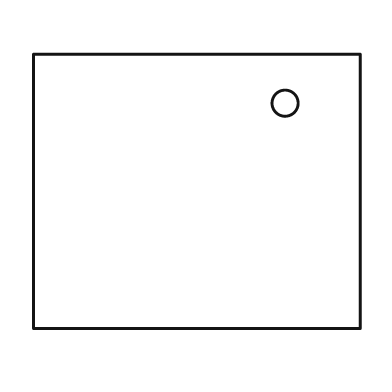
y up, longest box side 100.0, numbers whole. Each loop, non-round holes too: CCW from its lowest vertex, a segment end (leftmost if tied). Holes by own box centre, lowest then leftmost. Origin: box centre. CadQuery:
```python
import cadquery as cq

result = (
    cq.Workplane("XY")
    .moveTo(-50.0, -42.0)
    .lineTo(50.0, -42.0)
    .lineTo(50.0, 42.0)
    .lineTo(-50.0, 42.0)
    .close()
    .moveTo(27.0, 27.0)
    .circle(4.0)
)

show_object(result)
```